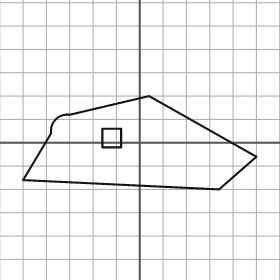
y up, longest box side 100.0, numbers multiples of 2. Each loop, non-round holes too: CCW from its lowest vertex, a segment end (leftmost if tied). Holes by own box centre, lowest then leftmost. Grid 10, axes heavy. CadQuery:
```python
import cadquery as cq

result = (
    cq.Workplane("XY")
    .moveTo(34.0, -20.0)
    .lineTo(50.0, -6.0)
    .lineTo(4.0, 20.0)
    .lineTo(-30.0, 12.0)
    .threePointArc((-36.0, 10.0), (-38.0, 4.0))
    .lineTo(-50.0, -16.0)
    .close()
    .moveTo(-16.0, -2.0)
    .lineTo(-8.0, -2.0)
    .lineTo(-8.0, 6.0)
    .lineTo(-16.0, 6.0)
    .close()
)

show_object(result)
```